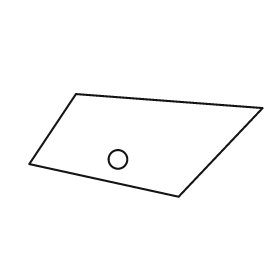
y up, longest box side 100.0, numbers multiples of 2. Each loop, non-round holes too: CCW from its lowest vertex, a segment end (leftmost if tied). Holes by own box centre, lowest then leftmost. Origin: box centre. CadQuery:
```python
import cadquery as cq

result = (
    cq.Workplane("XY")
    .moveTo(14.0, -22.0)
    .lineTo(50.0, 16.0)
    .lineTo(-30.0, 22.0)
    .lineTo(-50.0, -8.0)
    .close()
    .moveTo(-12.0, -6.0)
    .circle(4.0)
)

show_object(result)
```